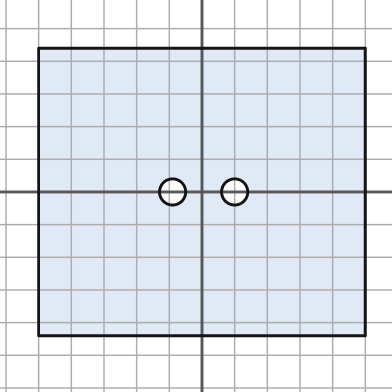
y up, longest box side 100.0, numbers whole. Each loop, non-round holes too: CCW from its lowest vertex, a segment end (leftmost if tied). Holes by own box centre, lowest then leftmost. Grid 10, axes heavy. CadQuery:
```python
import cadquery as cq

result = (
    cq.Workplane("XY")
    .moveTo(-50.0, -44.0)
    .lineTo(50.0, -44.0)
    .lineTo(50.0, 44.0)
    .lineTo(-50.0, 44.0)
    .close()
    .moveTo(-9.0, 0.0)
    .circle(4.0)
    .moveTo(10.0, 0.0)
    .circle(4.0)
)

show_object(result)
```